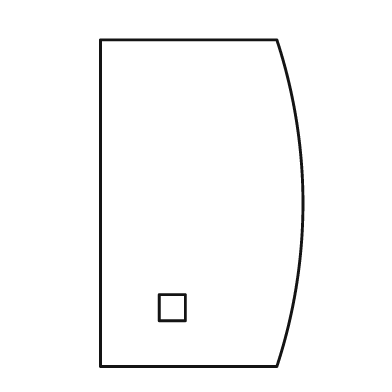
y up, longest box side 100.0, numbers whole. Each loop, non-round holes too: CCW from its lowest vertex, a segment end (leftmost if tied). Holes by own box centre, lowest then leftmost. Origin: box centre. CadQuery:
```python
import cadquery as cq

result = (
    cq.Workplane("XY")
    .moveTo(-31.0, -50.0)
    .lineTo(23.0, -50.0)
    .threePointArc((31.0, 0.0), (23.0, 50.0))
    .lineTo(-31.0, 50.0)
    .close()
    .moveTo(-13.0, -36.0)
    .lineTo(-5.0, -36.0)
    .lineTo(-5.0, -28.0)
    .lineTo(-13.0, -28.0)
    .close()
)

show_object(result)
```